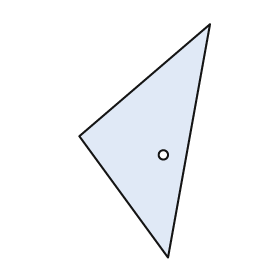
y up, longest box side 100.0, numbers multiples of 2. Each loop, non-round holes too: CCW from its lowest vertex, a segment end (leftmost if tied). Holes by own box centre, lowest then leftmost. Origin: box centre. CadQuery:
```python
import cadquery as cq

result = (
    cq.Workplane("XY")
    .moveTo(10.0, -50.0)
    .lineTo(28.0, 50.0)
    .lineTo(-28.0, 2.0)
    .close()
    .moveTo(8.0, -6.0)
    .circle(2.0)
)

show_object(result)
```